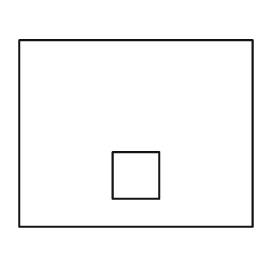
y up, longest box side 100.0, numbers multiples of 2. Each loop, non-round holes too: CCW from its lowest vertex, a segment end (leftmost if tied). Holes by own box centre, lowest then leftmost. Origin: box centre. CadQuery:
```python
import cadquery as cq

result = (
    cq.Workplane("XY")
    .moveTo(-50.0, -40.0)
    .lineTo(50.0, -40.0)
    .lineTo(50.0, 40.0)
    .lineTo(-50.0, 40.0)
    .close()
    .moveTo(-10.0, -28.0)
    .lineTo(10.0, -28.0)
    .lineTo(10.0, -8.0)
    .lineTo(-10.0, -8.0)
    .close()
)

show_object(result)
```